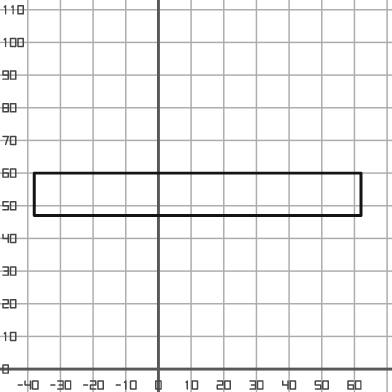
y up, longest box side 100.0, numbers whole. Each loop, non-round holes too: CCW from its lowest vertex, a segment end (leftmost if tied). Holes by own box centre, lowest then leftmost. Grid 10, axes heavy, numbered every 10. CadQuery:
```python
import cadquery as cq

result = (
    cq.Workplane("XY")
    .moveTo(-38.0, 47.0)
    .lineTo(62.0, 47.0)
    .lineTo(62.0, 60.0)
    .lineTo(-38.0, 60.0)
    .close()
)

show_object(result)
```